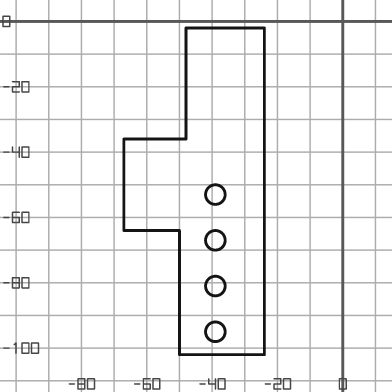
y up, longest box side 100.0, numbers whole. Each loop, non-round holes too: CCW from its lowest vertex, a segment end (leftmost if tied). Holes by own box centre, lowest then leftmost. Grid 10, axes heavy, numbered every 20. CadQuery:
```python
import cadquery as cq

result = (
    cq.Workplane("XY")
    .moveTo(-50.0, -102.0)
    .lineTo(-24.0, -102.0)
    .lineTo(-24.0, -2.0)
    .lineTo(-48.0, -2.0)
    .lineTo(-48.0, -36.0)
    .lineTo(-67.0, -36.0)
    .lineTo(-67.0, -64.0)
    .lineTo(-50.0, -64.0)
    .close()
    .moveTo(-39.0, -95.0)
    .circle(3.0)
    .moveTo(-39.0, -81.0)
    .circle(3.0)
    .moveTo(-39.0, -67.0)
    .circle(3.0)
    .moveTo(-39.0, -53.0)
    .circle(3.0)
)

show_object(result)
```